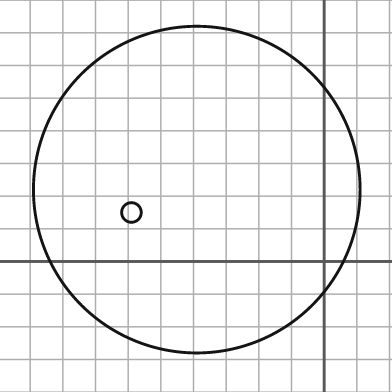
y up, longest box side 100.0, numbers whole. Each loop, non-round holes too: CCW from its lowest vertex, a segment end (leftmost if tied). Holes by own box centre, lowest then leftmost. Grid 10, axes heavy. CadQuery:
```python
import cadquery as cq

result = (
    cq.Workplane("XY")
    .moveTo(-39.0, 22.0)
    .circle(50.0)
    .moveTo(-59.0, 15.0)
    .circle(3.0)
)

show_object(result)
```